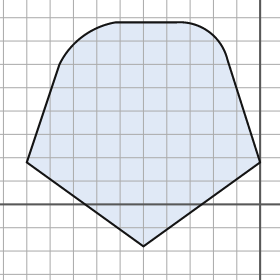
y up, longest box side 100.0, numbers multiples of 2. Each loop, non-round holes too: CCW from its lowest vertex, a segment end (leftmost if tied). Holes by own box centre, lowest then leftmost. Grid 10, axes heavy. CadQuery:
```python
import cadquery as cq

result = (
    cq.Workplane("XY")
    .moveTo(-50.0, -18.0)
    .lineTo(0.0, 18.0)
    .lineTo(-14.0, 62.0)
    .threePointArc((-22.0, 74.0), (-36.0, 78.0))
    .lineTo(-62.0, 78.0)
    .threePointArc((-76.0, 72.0), (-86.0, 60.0))
    .lineTo(-100.0, 18.0)
    .close()
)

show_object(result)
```